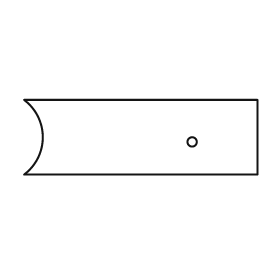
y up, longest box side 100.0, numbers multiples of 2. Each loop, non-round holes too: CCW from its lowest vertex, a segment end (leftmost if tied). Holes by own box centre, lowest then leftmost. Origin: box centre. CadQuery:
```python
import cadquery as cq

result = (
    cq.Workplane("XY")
    .moveTo(-50.0, -16.0)
    .lineTo(50.0, -16.0)
    .lineTo(50.0, 16.0)
    .lineTo(-50.0, 16.0)
    .threePointArc((-42.0, 0.0), (-50.0, -16.0))
    .close()
    .moveTo(22.0, -2.0)
    .circle(2.0)
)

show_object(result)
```